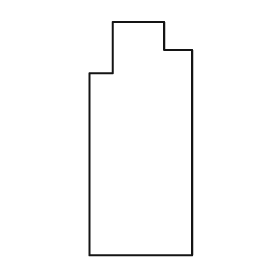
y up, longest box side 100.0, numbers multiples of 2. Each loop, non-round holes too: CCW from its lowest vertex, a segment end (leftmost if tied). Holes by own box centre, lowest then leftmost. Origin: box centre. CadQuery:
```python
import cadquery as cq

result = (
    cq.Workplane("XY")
    .moveTo(-22.0, -50.0)
    .lineTo(22.0, -50.0)
    .lineTo(22.0, 38.0)
    .lineTo(10.0, 38.0)
    .lineTo(10.0, 50.0)
    .lineTo(-12.0, 50.0)
    .lineTo(-12.0, 28.0)
    .lineTo(-22.0, 28.0)
    .close()
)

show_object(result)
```